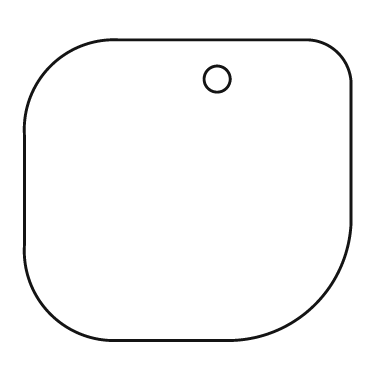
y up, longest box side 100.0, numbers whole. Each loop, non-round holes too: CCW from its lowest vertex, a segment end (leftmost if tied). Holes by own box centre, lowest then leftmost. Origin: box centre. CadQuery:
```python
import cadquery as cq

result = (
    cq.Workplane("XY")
    .moveTo(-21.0, -46.0)
    .lineTo(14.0, -46.0)
    .threePointArc((39.0, -35.0), (50.0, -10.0))
    .lineTo(50.0, 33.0)
    .threePointArc((46.0, 42.0), (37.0, 46.0))
    .lineTo(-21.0, 46.0)
    .threePointArc((-42.0, 38.0), (-50.0, 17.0))
    .lineTo(-50.0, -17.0)
    .threePointArc((-42.0, -38.0), (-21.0, -46.0))
    .close()
    .moveTo(9.0, 34.0)
    .circle(4.0)
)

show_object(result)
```